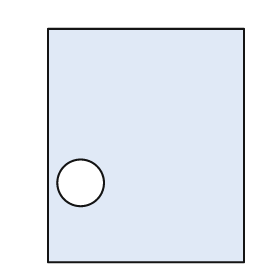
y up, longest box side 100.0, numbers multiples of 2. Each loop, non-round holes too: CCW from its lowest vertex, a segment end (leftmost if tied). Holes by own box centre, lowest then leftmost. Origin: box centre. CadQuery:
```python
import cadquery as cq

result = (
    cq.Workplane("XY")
    .moveTo(-42.0, -50.0)
    .lineTo(42.0, -50.0)
    .lineTo(42.0, 50.0)
    .lineTo(-42.0, 50.0)
    .close()
    .moveTo(-28.0, -16.0)
    .circle(10.0)
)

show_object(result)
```